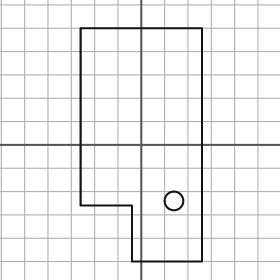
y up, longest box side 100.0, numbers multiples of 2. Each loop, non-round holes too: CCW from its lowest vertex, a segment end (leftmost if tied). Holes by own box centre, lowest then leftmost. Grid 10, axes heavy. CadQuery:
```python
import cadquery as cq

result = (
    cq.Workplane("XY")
    .moveTo(-4.0, -50.0)
    .lineTo(26.0, -50.0)
    .lineTo(26.0, 50.0)
    .lineTo(-26.0, 50.0)
    .lineTo(-26.0, -26.0)
    .lineTo(-4.0, -26.0)
    .close()
    .moveTo(14.0, -24.0)
    .circle(4.0)
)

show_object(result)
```